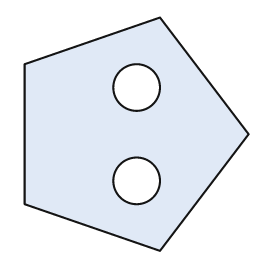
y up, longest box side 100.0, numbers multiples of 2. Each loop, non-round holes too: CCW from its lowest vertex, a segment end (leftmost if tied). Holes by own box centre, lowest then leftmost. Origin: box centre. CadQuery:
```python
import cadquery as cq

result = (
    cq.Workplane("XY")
    .moveTo(10.0, -50.0)
    .lineTo(48.0, 0.0)
    .lineTo(10.0, 50.0)
    .lineTo(-48.0, 30.0)
    .lineTo(-48.0, -30.0)
    .close()
    .moveTo(0.0, -20.0)
    .circle(10.0)
    .moveTo(0.0, 20.0)
    .circle(10.0)
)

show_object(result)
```